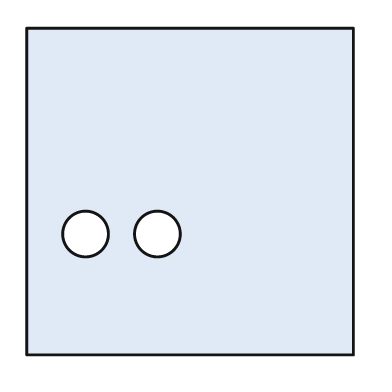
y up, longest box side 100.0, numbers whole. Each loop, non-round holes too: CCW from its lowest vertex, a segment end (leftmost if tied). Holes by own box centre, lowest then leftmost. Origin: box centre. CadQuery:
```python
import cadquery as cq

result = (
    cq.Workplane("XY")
    .moveTo(-50.0, -50.0)
    .lineTo(50.0, -50.0)
    .lineTo(50.0, 50.0)
    .lineTo(-50.0, 50.0)
    .close()
    .moveTo(-32.0, -13.0)
    .circle(7.0)
    .moveTo(-10.0, -13.0)
    .circle(7.0)
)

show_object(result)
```